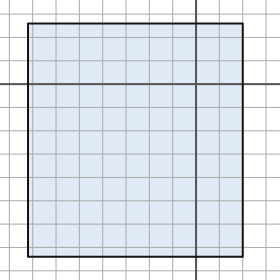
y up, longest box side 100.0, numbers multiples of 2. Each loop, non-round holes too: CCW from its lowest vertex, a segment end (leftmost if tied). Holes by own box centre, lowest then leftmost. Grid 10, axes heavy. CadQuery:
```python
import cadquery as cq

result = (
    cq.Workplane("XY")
    .moveTo(-72.0, -74.0)
    .lineTo(20.0, -74.0)
    .lineTo(20.0, 26.0)
    .lineTo(-72.0, 26.0)
    .close()
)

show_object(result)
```